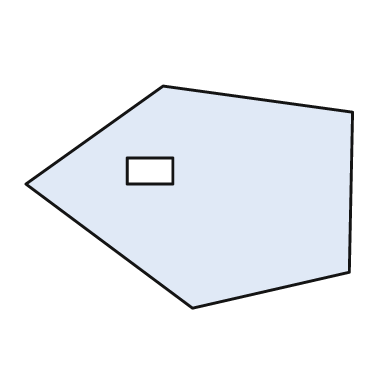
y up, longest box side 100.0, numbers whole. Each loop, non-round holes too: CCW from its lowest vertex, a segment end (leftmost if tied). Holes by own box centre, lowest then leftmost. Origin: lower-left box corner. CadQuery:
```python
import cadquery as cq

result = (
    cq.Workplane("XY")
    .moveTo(51.0, 0.0)
    .lineTo(99.0, 11.0)
    .lineTo(100.0, 60.0)
    .lineTo(42.0, 68.0)
    .lineTo(0.0, 38.0)
    .close()
    .moveTo(31.0, 38.0)
    .lineTo(45.0, 38.0)
    .lineTo(45.0, 46.0)
    .lineTo(31.0, 46.0)
    .close()
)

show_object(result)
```